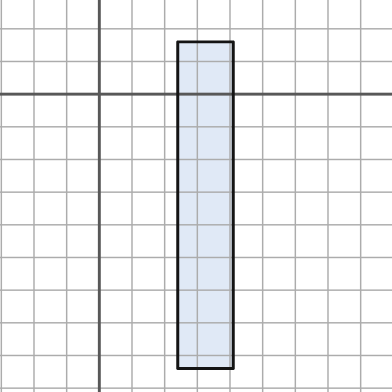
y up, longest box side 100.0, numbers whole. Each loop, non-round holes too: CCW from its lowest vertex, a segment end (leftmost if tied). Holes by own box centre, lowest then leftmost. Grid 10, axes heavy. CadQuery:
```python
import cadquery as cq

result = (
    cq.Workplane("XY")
    .moveTo(24.0, -84.0)
    .lineTo(41.0, -84.0)
    .lineTo(41.0, 16.0)
    .lineTo(24.0, 16.0)
    .close()
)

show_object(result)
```